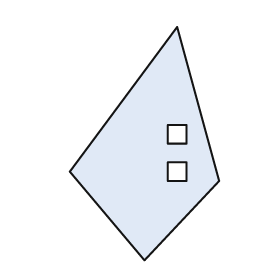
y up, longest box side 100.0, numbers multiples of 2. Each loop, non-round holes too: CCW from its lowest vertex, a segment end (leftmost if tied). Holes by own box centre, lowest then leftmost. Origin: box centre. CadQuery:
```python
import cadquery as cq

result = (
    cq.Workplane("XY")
    .moveTo(0.0, -50.0)
    .lineTo(32.0, -16.0)
    .lineTo(14.0, 50.0)
    .lineTo(-32.0, -12.0)
    .close()
    .moveTo(10.0, -16.0)
    .lineTo(18.0, -16.0)
    .lineTo(18.0, -8.0)
    .lineTo(10.0, -8.0)
    .close()
    .moveTo(10.0, 0.0)
    .lineTo(18.0, 0.0)
    .lineTo(18.0, 8.0)
    .lineTo(10.0, 8.0)
    .close()
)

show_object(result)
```